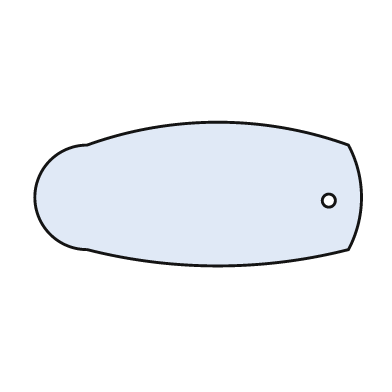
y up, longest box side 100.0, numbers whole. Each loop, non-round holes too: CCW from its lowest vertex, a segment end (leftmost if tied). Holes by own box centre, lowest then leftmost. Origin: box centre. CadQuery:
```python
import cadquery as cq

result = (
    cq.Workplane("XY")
    .moveTo(-34.0, -17.0)
    .threePointArc((6.0, -22.0), (46.0, -17.0))
    .threePointArc((50.0, -1.0), (46.0, 15.0))
    .threePointArc((6.0, 22.0), (-34.0, 15.0))
    .threePointArc((-50.0, -1.0), (-34.0, -17.0))
    .close()
    .moveTo(40.0, -2.0)
    .circle(2.0)
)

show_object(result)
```